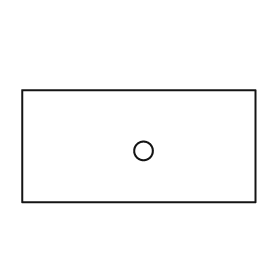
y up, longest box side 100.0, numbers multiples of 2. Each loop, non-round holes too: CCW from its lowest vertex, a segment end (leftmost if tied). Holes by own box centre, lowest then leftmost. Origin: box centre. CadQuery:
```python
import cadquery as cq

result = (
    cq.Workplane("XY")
    .moveTo(-50.0, -24.0)
    .lineTo(50.0, -24.0)
    .lineTo(50.0, 24.0)
    .lineTo(-50.0, 24.0)
    .close()
    .moveTo(2.0, -2.0)
    .circle(4.0)
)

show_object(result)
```